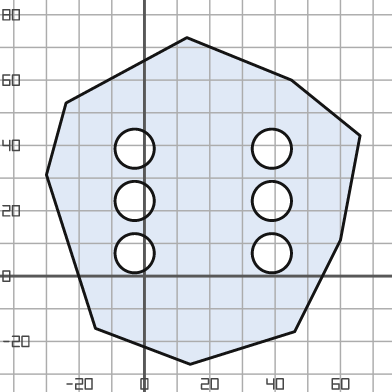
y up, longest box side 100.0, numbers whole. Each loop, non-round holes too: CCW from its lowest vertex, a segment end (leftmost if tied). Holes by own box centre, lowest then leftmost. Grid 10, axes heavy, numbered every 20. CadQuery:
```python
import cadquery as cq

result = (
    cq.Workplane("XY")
    .moveTo(14.0, -27.0)
    .lineTo(46.0, -17.0)
    .lineTo(60.0, 11.0)
    .lineTo(66.0, 43.0)
    .lineTo(45.0, 60.0)
    .lineTo(13.0, 73.0)
    .lineTo(-24.0, 53.0)
    .lineTo(-30.0, 31.0)
    .lineTo(-15.0, -16.0)
    .close()
    .moveTo(-3.0, 7.0)
    .circle(6.0)
    .moveTo(39.0, 7.0)
    .circle(6.0)
    .moveTo(-3.0, 23.0)
    .circle(6.0)
    .moveTo(39.0, 23.0)
    .circle(6.0)
    .moveTo(-3.0, 39.0)
    .circle(6.0)
    .moveTo(39.0, 39.0)
    .circle(6.0)
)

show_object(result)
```